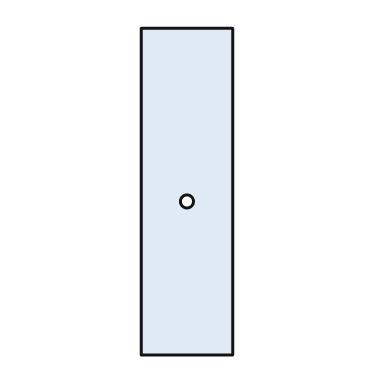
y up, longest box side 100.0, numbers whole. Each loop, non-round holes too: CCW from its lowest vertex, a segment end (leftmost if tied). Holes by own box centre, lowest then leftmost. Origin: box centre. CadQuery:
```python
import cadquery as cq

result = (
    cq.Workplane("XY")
    .moveTo(-14.0, -50.0)
    .lineTo(14.0, -50.0)
    .lineTo(14.0, 50.0)
    .lineTo(-14.0, 50.0)
    .close()
    .moveTo(0.0, -3.0)
    .circle(2.0)
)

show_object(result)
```